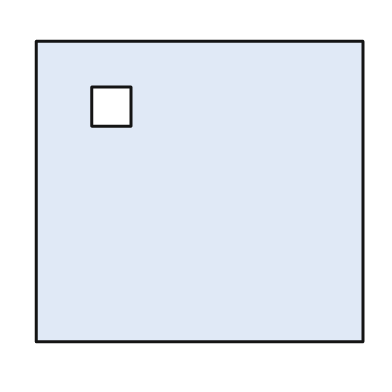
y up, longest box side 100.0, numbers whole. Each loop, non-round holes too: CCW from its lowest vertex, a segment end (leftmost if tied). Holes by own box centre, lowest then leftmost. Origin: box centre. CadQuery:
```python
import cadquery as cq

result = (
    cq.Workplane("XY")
    .moveTo(-50.0, -46.0)
    .lineTo(50.0, -46.0)
    .lineTo(50.0, 46.0)
    .lineTo(-50.0, 46.0)
    .close()
    .moveTo(-33.0, 20.0)
    .lineTo(-21.0, 20.0)
    .lineTo(-21.0, 32.0)
    .lineTo(-33.0, 32.0)
    .close()
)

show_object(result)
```